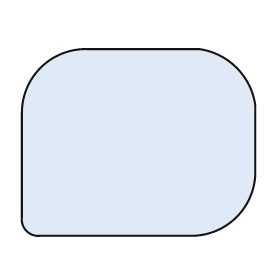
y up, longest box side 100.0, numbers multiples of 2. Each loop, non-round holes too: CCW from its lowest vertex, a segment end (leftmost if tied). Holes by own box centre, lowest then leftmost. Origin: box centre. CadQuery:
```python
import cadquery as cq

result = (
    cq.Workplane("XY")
    .moveTo(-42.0, -40.0)
    .lineTo(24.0, -40.0)
    .threePointArc((42.0, -32.0), (50.0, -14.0))
    .lineTo(50.0, 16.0)
    .threePointArc((42.0, 32.0), (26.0, 40.0))
    .lineTo(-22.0, 40.0)
    .threePointArc((-42.0, 32.0), (-50.0, 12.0))
    .lineTo(-50.0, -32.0)
    .threePointArc((-48.0, -38.0), (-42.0, -40.0))
    .close()
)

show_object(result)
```